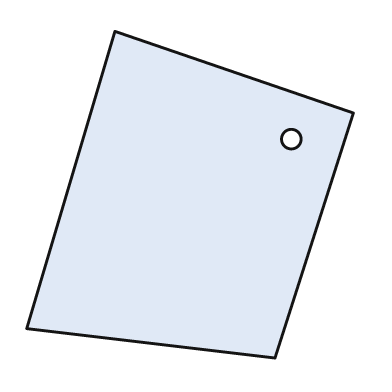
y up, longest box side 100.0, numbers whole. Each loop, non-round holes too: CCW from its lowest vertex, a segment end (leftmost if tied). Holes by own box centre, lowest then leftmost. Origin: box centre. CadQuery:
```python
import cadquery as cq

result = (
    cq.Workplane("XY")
    .moveTo(26.0, -50.0)
    .lineTo(50.0, 25.0)
    .lineTo(-23.0, 50.0)
    .lineTo(-50.0, -41.0)
    .close()
    .moveTo(31.0, 17.0)
    .circle(3.0)
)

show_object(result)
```